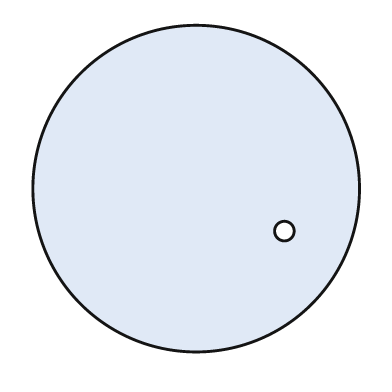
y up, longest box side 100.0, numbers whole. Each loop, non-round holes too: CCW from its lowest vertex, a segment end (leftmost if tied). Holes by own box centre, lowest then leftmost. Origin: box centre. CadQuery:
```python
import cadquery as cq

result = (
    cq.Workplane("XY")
    .moveTo(0.0, 0.0)
    .circle(50.0)
    .moveTo(27.0, -13.0)
    .circle(3.0)
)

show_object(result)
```